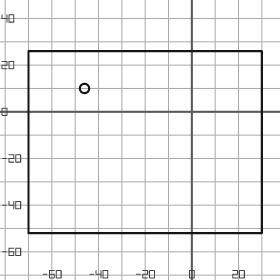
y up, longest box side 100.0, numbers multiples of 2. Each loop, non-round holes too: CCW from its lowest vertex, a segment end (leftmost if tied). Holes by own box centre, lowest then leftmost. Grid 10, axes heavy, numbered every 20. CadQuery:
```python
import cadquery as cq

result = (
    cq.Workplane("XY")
    .moveTo(-70.0, -52.0)
    .lineTo(30.0, -52.0)
    .lineTo(30.0, 26.0)
    .lineTo(-70.0, 26.0)
    .close()
    .moveTo(-46.0, 10.0)
    .circle(2.0)
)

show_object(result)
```